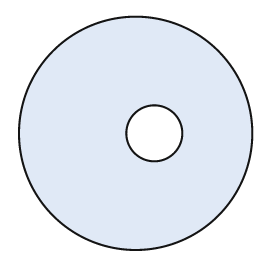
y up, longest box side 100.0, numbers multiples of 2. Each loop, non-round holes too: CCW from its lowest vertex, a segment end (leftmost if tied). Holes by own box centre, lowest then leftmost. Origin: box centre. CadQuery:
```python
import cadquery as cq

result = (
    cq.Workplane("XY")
    .moveTo(0.0, 0.0)
    .circle(50.0)
    .moveTo(8.0, 0.0)
    .circle(12.0)
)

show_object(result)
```